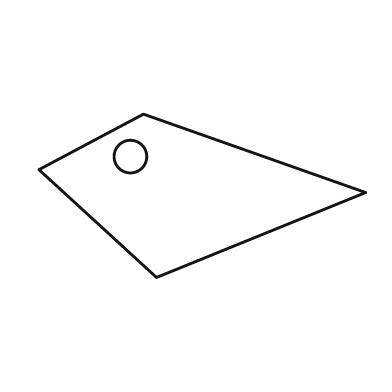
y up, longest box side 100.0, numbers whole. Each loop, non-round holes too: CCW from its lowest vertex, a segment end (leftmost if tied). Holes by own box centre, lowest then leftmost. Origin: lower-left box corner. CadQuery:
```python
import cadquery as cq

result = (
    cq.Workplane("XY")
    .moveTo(36.0, 0.0)
    .lineTo(100.0, 26.0)
    .lineTo(32.0, 50.0)
    .lineTo(0.0, 33.0)
    .close()
    .moveTo(28.0, 37.0)
    .circle(5.0)
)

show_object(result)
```